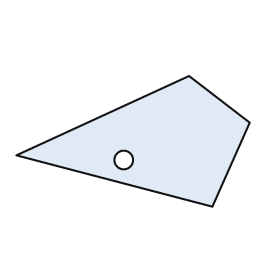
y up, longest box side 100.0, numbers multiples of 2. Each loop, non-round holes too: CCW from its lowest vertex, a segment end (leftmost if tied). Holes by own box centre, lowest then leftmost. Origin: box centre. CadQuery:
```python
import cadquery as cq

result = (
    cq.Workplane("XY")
    .moveTo(34.0, -28.0)
    .lineTo(50.0, 8.0)
    .lineTo(24.0, 28.0)
    .lineTo(-50.0, -6.0)
    .close()
    .moveTo(-4.0, -8.0)
    .circle(4.0)
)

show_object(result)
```